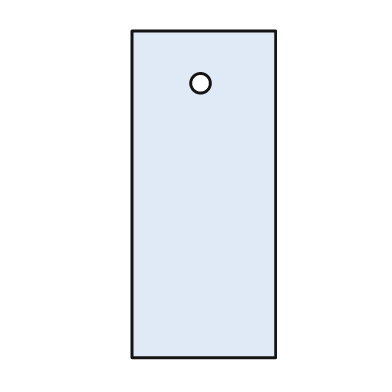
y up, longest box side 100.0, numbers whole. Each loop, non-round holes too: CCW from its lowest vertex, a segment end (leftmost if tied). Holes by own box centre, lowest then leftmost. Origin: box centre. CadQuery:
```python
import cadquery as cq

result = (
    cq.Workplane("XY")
    .moveTo(-22.0, -50.0)
    .lineTo(22.0, -50.0)
    .lineTo(22.0, 50.0)
    .lineTo(-22.0, 50.0)
    .close()
    .moveTo(-1.0, 34.0)
    .circle(3.0)
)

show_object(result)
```